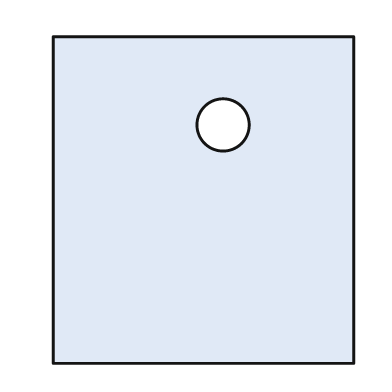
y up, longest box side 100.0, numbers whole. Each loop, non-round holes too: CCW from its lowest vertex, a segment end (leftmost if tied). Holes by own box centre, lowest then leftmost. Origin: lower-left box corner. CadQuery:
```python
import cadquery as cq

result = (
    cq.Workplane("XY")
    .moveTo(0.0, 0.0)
    .lineTo(92.0, 0.0)
    .lineTo(92.0, 100.0)
    .lineTo(0.0, 100.0)
    .close()
    .moveTo(52.0, 73.0)
    .circle(8.0)
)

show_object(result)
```